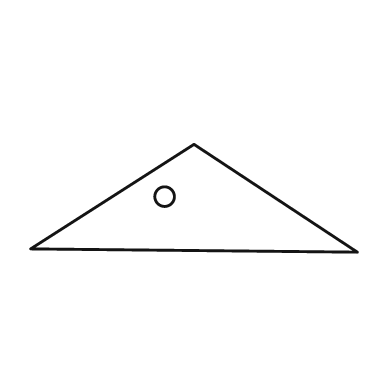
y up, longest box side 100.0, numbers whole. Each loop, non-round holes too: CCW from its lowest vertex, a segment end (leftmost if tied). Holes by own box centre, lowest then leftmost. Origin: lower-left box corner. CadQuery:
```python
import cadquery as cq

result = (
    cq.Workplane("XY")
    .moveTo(100.0, 0.0)
    .lineTo(50.0, 33.0)
    .lineTo(0.0, 1.0)
    .close()
    .moveTo(41.0, 17.0)
    .circle(3.0)
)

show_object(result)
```